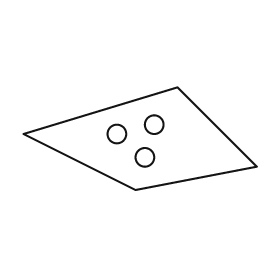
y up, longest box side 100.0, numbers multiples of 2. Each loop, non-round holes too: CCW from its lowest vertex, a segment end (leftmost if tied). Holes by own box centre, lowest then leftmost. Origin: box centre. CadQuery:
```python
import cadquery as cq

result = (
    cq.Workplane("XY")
    .moveTo(-2.0, -22.0)
    .lineTo(50.0, -12.0)
    .lineTo(16.0, 22.0)
    .lineTo(-50.0, 2.0)
    .close()
    .moveTo(2.0, -8.0)
    .circle(4.0)
    .moveTo(-10.0, 2.0)
    .circle(4.0)
    .moveTo(6.0, 6.0)
    .circle(4.0)
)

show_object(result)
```